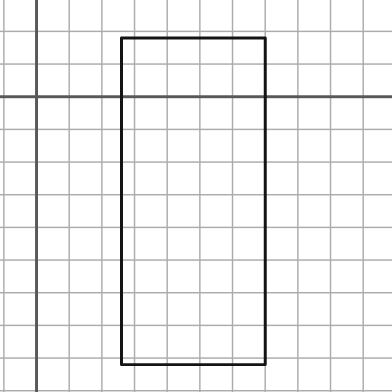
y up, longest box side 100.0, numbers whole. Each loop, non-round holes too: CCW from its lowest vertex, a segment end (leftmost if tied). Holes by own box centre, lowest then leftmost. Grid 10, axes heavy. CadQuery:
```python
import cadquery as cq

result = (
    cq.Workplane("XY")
    .moveTo(26.0, -82.0)
    .lineTo(70.0, -82.0)
    .lineTo(70.0, 18.0)
    .lineTo(26.0, 18.0)
    .close()
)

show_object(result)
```